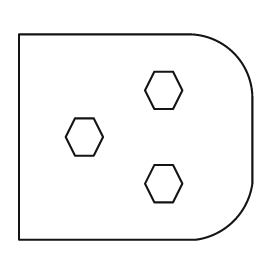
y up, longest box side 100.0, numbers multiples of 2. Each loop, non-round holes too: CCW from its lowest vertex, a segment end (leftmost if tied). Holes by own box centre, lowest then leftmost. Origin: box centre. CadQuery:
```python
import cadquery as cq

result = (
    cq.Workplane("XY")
    .moveTo(-50.0, -44.0)
    .lineTo(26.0, -44.0)
    .threePointArc((42.0, -36.0), (50.0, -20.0))
    .lineTo(50.0, 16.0)
    .threePointArc((42.0, 36.0), (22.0, 44.0))
    .lineTo(-50.0, 44.0)
    .close()
    .moveTo(8.0, -28.0)
    .lineTo(16.0, -28.0)
    .lineTo(20.0, -20.0)
    .lineTo(16.0, -12.0)
    .lineTo(8.0, -12.0)
    .lineTo(4.0, -20.0)
    .close()
    .moveTo(-26.0, -8.0)
    .lineTo(-18.0, -8.0)
    .lineTo(-14.0, 0.0)
    .lineTo(-18.0, 8.0)
    .lineTo(-26.0, 8.0)
    .lineTo(-30.0, 0.0)
    .close()
    .moveTo(8.0, 12.0)
    .lineTo(16.0, 12.0)
    .lineTo(20.0, 20.0)
    .lineTo(16.0, 28.0)
    .lineTo(8.0, 28.0)
    .lineTo(4.0, 20.0)
    .close()
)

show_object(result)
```